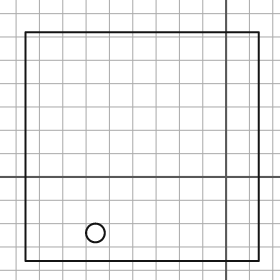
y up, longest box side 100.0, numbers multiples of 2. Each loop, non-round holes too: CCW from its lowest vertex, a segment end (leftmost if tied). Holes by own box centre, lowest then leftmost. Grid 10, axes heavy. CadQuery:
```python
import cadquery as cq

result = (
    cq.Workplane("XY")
    .moveTo(-86.0, -36.0)
    .lineTo(14.0, -36.0)
    .lineTo(14.0, 62.0)
    .lineTo(-86.0, 62.0)
    .close()
    .moveTo(-56.0, -24.0)
    .circle(4.0)
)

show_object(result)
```